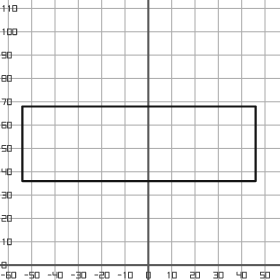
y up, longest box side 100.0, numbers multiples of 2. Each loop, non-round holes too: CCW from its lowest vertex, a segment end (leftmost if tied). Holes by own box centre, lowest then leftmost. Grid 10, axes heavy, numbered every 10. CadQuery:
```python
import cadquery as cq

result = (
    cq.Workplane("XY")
    .moveTo(-54.0, 36.0)
    .lineTo(46.0, 36.0)
    .lineTo(46.0, 68.0)
    .lineTo(-54.0, 68.0)
    .close()
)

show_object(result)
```